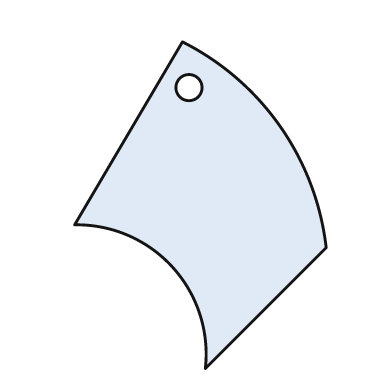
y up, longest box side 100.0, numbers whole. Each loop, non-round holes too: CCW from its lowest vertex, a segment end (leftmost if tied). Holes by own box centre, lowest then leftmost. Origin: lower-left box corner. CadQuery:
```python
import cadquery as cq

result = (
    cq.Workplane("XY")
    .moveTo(40.0, 0.0)
    .lineTo(77.0, 37.0)
    .threePointArc((63.0, 74.0), (33.0, 100.0))
    .lineTo(0.0, 44.0)
    .threePointArc((30.0, 31.0), (40.0, 0.0))
    .close()
    .moveTo(35.0, 86.0)
    .circle(4.0)
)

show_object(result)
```